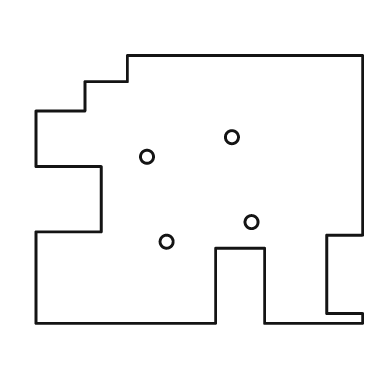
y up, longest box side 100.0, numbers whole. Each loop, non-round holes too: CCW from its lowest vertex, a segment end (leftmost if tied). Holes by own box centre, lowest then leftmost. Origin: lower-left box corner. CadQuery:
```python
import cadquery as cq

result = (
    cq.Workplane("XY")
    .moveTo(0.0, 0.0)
    .lineTo(55.0, 0.0)
    .lineTo(55.0, 23.0)
    .lineTo(70.0, 23.0)
    .lineTo(70.0, 0.0)
    .lineTo(100.0, 0.0)
    .lineTo(100.0, 3.0)
    .lineTo(89.0, 3.0)
    .lineTo(89.0, 27.0)
    .lineTo(100.0, 27.0)
    .lineTo(100.0, 82.0)
    .lineTo(28.0, 82.0)
    .lineTo(28.0, 74.0)
    .lineTo(15.0, 74.0)
    .lineTo(15.0, 65.0)
    .lineTo(0.0, 65.0)
    .lineTo(0.0, 48.0)
    .lineTo(20.0, 48.0)
    .lineTo(20.0, 28.0)
    .lineTo(0.0, 28.0)
    .close()
    .moveTo(40.0, 25.0)
    .circle(2.0)
    .moveTo(66.0, 31.0)
    .circle(2.0)
    .moveTo(34.0, 51.0)
    .circle(2.0)
    .moveTo(60.0, 57.0)
    .circle(2.0)
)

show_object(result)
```